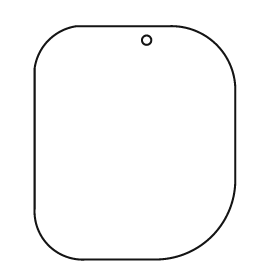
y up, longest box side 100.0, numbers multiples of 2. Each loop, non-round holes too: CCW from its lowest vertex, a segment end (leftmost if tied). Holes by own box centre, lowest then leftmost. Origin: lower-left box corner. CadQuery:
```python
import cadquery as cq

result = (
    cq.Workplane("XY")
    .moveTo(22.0, 0.0)
    .lineTo(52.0, 0.0)
    .threePointArc((76.0, 10.0), (86.0, 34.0))
    .lineTo(86.0, 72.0)
    .threePointArc((78.0, 92.0), (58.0, 100.0))
    .lineTo(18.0, 100.0)
    .threePointArc((6.0, 94.0), (0.0, 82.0))
    .lineTo(0.0, 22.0)
    .threePointArc((6.0, 6.0), (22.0, 0.0))
    .close()
    .moveTo(48.0, 94.0)
    .circle(2.0)
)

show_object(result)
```